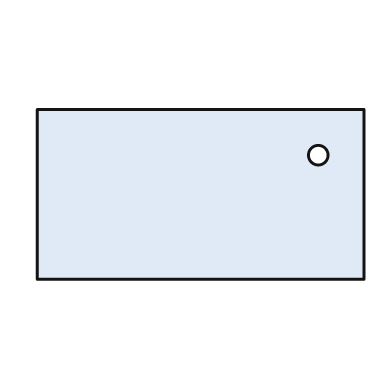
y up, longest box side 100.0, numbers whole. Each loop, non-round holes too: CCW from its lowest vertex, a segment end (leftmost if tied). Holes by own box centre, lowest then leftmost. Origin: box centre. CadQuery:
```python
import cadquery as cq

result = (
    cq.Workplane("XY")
    .moveTo(-50.0, -26.0)
    .lineTo(50.0, -26.0)
    .lineTo(50.0, 26.0)
    .lineTo(-50.0, 26.0)
    .close()
    .moveTo(36.0, 12.0)
    .circle(3.0)
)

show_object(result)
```